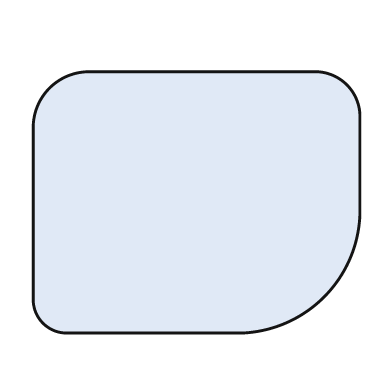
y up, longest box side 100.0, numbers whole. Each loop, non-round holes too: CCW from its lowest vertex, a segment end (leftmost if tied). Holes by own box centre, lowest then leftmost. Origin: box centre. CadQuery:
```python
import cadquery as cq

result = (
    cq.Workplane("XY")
    .moveTo(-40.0, -40.0)
    .lineTo(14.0, -40.0)
    .threePointArc((39.0, -29.0), (50.0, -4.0))
    .lineTo(50.0, 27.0)
    .threePointArc((46.0, 36.0), (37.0, 40.0))
    .lineTo(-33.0, 40.0)
    .threePointArc((-45.0, 35.0), (-50.0, 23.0))
    .lineTo(-50.0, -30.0)
    .threePointArc((-47.0, -37.0), (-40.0, -40.0))
    .close()
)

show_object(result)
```